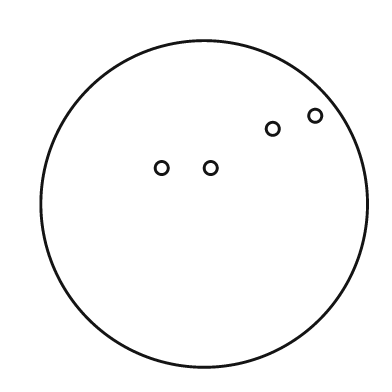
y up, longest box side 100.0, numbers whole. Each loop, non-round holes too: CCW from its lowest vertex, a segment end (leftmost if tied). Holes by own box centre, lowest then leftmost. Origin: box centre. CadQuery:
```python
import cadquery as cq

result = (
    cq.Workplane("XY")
    .moveTo(0.0, 0.0)
    .circle(50.0)
    .moveTo(-13.0, 11.0)
    .circle(2.0)
    .moveTo(2.0, 11.0)
    .circle(2.0)
    .moveTo(21.0, 23.0)
    .circle(2.0)
    .moveTo(34.0, 27.0)
    .circle(2.0)
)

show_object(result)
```